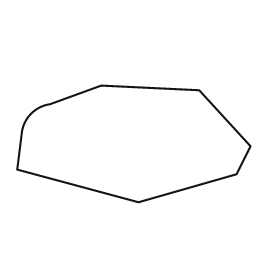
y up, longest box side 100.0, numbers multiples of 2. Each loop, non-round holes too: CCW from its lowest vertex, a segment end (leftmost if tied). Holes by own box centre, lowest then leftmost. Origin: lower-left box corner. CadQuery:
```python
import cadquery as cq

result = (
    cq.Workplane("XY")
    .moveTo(52.0, 0.0)
    .lineTo(94.0, 12.0)
    .lineTo(100.0, 24.0)
    .lineTo(78.0, 48.0)
    .lineTo(36.0, 50.0)
    .lineTo(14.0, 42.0)
    .threePointArc((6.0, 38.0), (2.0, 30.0))
    .lineTo(0.0, 14.0)
    .close()
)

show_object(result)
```